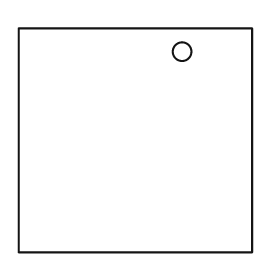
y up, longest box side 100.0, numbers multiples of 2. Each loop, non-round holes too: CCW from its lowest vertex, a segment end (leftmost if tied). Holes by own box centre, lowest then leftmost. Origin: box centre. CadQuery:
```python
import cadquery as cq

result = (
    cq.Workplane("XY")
    .moveTo(-50.0, -48.0)
    .lineTo(50.0, -48.0)
    .lineTo(50.0, 48.0)
    .lineTo(-50.0, 48.0)
    .close()
    .moveTo(20.0, 38.0)
    .circle(4.0)
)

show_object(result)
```